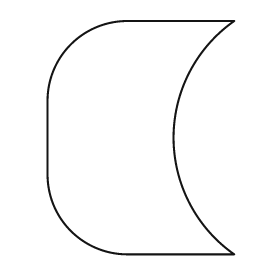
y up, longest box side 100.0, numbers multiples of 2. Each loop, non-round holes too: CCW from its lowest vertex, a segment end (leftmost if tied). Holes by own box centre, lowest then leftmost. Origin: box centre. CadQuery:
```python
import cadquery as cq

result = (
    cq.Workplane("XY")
    .moveTo(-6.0, -50.0)
    .lineTo(40.0, -50.0)
    .threePointArc((14.0, 0.0), (40.0, 50.0))
    .lineTo(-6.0, 50.0)
    .threePointArc((-30.0, 40.0), (-40.0, 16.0))
    .lineTo(-40.0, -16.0)
    .threePointArc((-30.0, -40.0), (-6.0, -50.0))
    .close()
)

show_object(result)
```